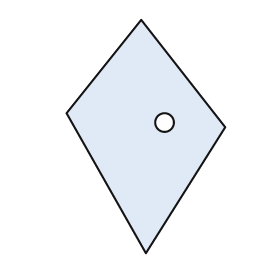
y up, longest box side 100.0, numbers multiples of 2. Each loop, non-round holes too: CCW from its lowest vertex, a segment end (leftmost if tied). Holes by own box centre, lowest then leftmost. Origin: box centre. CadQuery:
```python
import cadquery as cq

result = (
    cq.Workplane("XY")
    .moveTo(0.0, -50.0)
    .lineTo(34.0, 4.0)
    .lineTo(-2.0, 50.0)
    .lineTo(-34.0, 10.0)
    .close()
    .moveTo(8.0, 6.0)
    .circle(4.0)
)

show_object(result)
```